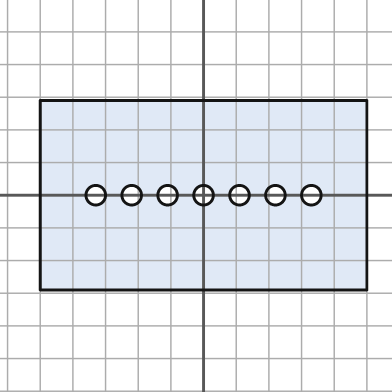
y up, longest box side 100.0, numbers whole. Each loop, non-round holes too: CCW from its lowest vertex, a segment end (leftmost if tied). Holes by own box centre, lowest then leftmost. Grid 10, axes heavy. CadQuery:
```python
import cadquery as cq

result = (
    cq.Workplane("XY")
    .moveTo(-50.0, -29.0)
    .lineTo(50.0, -29.0)
    .lineTo(50.0, 29.0)
    .lineTo(-50.0, 29.0)
    .close()
    .moveTo(-33.0, 0.0)
    .circle(3.0)
    .moveTo(-22.0, 0.0)
    .circle(3.0)
    .moveTo(-11.0, 0.0)
    .circle(3.0)
    .moveTo(0.0, 0.0)
    .circle(3.0)
    .moveTo(11.0, 0.0)
    .circle(3.0)
    .moveTo(22.0, 0.0)
    .circle(3.0)
    .moveTo(33.0, 0.0)
    .circle(3.0)
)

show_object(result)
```